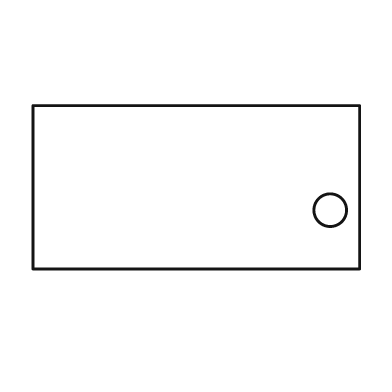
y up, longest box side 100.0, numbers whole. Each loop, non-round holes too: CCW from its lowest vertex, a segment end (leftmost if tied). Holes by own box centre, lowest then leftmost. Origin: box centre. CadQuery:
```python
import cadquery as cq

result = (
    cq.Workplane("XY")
    .moveTo(-50.0, -25.0)
    .lineTo(50.0, -25.0)
    .lineTo(50.0, 25.0)
    .lineTo(-50.0, 25.0)
    .close()
    .moveTo(41.0, -7.0)
    .circle(5.0)
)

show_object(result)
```